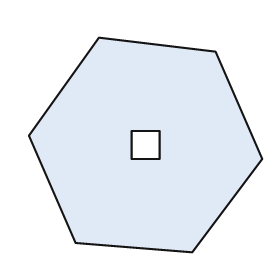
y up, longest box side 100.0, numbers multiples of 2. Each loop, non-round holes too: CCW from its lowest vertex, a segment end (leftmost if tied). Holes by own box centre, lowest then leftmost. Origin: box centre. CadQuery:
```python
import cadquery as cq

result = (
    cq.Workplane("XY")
    .moveTo(20.0, -46.0)
    .lineTo(50.0, -6.0)
    .lineTo(30.0, 40.0)
    .lineTo(-20.0, 46.0)
    .lineTo(-50.0, 4.0)
    .lineTo(-30.0, -42.0)
    .close()
    .moveTo(-6.0, -6.0)
    .lineTo(6.0, -6.0)
    .lineTo(6.0, 6.0)
    .lineTo(-6.0, 6.0)
    .close()
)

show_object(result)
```